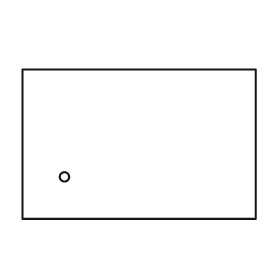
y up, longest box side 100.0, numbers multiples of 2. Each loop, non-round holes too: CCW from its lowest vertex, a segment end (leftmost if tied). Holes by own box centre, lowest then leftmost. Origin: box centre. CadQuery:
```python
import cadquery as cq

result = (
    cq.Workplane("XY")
    .moveTo(-50.0, -32.0)
    .lineTo(50.0, -32.0)
    .lineTo(50.0, 32.0)
    .lineTo(-50.0, 32.0)
    .close()
    .moveTo(-32.0, -14.0)
    .circle(2.0)
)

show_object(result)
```